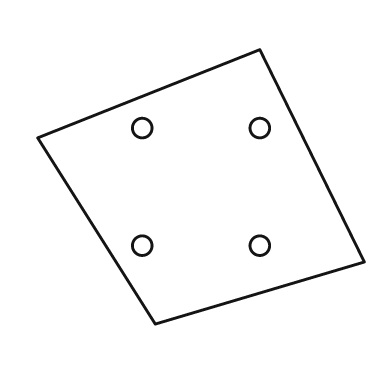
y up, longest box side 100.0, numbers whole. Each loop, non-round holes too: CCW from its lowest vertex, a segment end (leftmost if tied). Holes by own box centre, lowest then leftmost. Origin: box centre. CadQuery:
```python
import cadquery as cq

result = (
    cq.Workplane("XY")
    .moveTo(-14.0, -42.0)
    .lineTo(50.0, -23.0)
    .lineTo(18.0, 42.0)
    .lineTo(-50.0, 15.0)
    .close()
    .moveTo(-18.0, -18.0)
    .circle(3.0)
    .moveTo(18.0, -18.0)
    .circle(3.0)
    .moveTo(-18.0, 18.0)
    .circle(3.0)
    .moveTo(18.0, 18.0)
    .circle(3.0)
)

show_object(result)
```